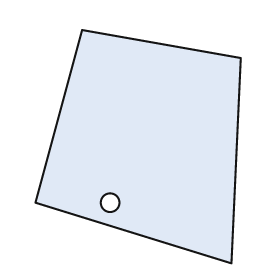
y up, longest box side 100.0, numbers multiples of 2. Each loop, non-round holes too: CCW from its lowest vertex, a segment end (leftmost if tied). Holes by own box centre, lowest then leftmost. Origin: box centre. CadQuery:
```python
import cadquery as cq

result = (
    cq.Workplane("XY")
    .moveTo(40.0, -50.0)
    .lineTo(44.0, 38.0)
    .lineTo(-24.0, 50.0)
    .lineTo(-44.0, -24.0)
    .close()
    .moveTo(-12.0, -24.0)
    .circle(4.0)
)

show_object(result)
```